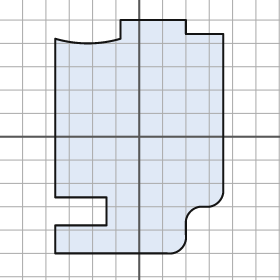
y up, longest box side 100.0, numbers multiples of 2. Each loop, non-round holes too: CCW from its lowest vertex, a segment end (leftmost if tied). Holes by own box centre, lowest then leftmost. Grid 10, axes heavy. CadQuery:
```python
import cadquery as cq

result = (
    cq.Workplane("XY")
    .moveTo(-36.0, -50.0)
    .lineTo(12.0, -50.0)
    .threePointArc((18.0, -48.0), (20.0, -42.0))
    .lineTo(20.0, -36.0)
    .threePointArc((22.0, -32.0), (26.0, -30.0))
    .lineTo(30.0, -30.0)
    .threePointArc((34.0, -28.0), (36.0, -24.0))
    .lineTo(36.0, 44.0)
    .lineTo(20.0, 44.0)
    .lineTo(20.0, 50.0)
    .lineTo(-8.0, 50.0)
    .lineTo(-8.0, 42.0)
    .threePointArc((-22.0, 40.0), (-36.0, 42.0))
    .lineTo(-36.0, -26.0)
    .lineTo(-14.0, -26.0)
    .lineTo(-14.0, -38.0)
    .lineTo(-36.0, -38.0)
    .close()
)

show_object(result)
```